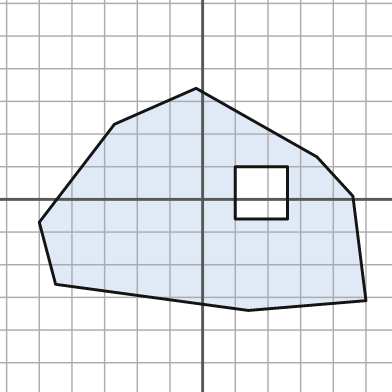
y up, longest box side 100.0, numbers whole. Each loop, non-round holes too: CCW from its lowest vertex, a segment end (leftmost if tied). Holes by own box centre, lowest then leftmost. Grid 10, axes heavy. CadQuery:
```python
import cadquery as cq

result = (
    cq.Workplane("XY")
    .moveTo(14.0, -34.0)
    .lineTo(50.0, -31.0)
    .lineTo(46.0, 1.0)
    .lineTo(35.0, 13.0)
    .lineTo(-2.0, 34.0)
    .lineTo(-27.0, 23.0)
    .lineTo(-50.0, -7.0)
    .lineTo(-45.0, -26.0)
    .close()
    .moveTo(10.0, -6.0)
    .lineTo(26.0, -6.0)
    .lineTo(26.0, 10.0)
    .lineTo(10.0, 10.0)
    .close()
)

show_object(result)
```